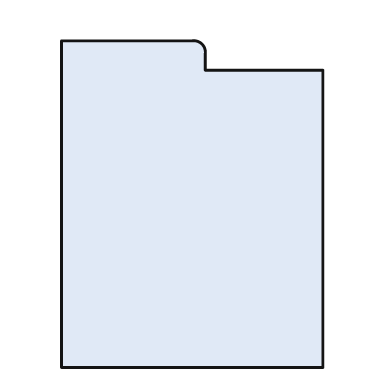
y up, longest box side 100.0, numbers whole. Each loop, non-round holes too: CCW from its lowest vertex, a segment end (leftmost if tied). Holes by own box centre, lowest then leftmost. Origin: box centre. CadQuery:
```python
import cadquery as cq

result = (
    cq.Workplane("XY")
    .moveTo(-40.0, -50.0)
    .lineTo(40.0, -50.0)
    .lineTo(40.0, 41.0)
    .lineTo(4.0, 41.0)
    .lineTo(4.0, 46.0)
    .threePointArc((3.0, 49.0), (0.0, 50.0))
    .lineTo(-40.0, 50.0)
    .close()
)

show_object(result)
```